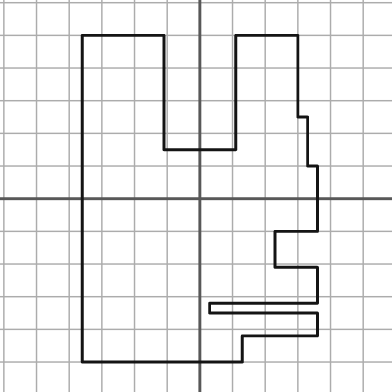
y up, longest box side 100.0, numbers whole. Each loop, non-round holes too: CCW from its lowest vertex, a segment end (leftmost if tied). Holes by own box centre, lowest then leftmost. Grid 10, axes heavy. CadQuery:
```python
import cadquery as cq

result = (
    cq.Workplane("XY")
    .moveTo(-36.0, -50.0)
    .lineTo(13.0, -50.0)
    .lineTo(13.0, -42.0)
    .lineTo(36.0, -42.0)
    .lineTo(36.0, -35.0)
    .lineTo(3.0, -35.0)
    .lineTo(3.0, -32.0)
    .lineTo(36.0, -32.0)
    .lineTo(36.0, -21.0)
    .lineTo(23.0, -21.0)
    .lineTo(23.0, -10.0)
    .lineTo(36.0, -10.0)
    .lineTo(36.0, 10.0)
    .lineTo(33.0, 10.0)
    .lineTo(33.0, 25.0)
    .lineTo(30.0, 25.0)
    .lineTo(30.0, 50.0)
    .lineTo(11.0, 50.0)
    .lineTo(11.0, 15.0)
    .lineTo(-11.0, 15.0)
    .lineTo(-11.0, 50.0)
    .lineTo(-36.0, 50.0)
    .close()
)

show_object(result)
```